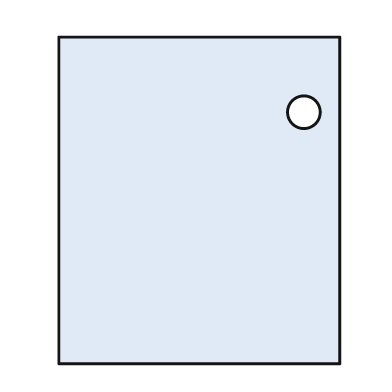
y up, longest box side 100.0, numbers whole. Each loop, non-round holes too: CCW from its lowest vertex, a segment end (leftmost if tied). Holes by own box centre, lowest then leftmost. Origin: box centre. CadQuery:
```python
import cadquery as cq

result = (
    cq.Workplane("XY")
    .moveTo(-43.0, -50.0)
    .lineTo(43.0, -50.0)
    .lineTo(43.0, 50.0)
    .lineTo(-43.0, 50.0)
    .close()
    .moveTo(32.0, 27.0)
    .circle(5.0)
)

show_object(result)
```